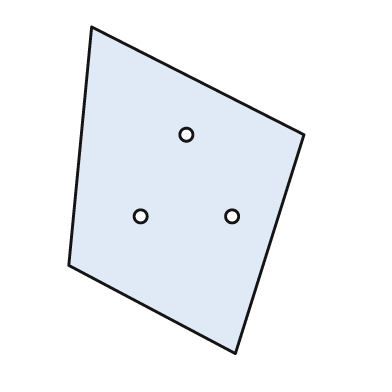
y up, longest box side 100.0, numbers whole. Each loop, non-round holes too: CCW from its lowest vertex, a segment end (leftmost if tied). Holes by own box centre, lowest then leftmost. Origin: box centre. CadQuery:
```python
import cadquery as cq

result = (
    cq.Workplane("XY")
    .moveTo(15.0, -50.0)
    .lineTo(36.0, 17.0)
    .lineTo(-29.0, 50.0)
    .lineTo(-36.0, -23.0)
    .close()
    .moveTo(-14.0, -8.0)
    .circle(2.0)
    .moveTo(14.0, -8.0)
    .circle(2.0)
    .moveTo(0.0, 17.0)
    .circle(2.0)
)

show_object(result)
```